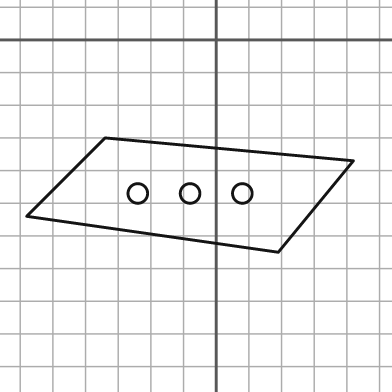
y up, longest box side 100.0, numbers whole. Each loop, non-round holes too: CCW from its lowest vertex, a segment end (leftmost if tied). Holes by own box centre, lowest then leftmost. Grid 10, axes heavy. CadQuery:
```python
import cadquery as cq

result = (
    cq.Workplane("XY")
    .moveTo(19.0, -65.0)
    .lineTo(42.0, -37.0)
    .lineTo(-34.0, -30.0)
    .lineTo(-58.0, -54.0)
    .close()
    .moveTo(-24.0, -47.0)
    .circle(3.0)
    .moveTo(-8.0, -47.0)
    .circle(3.0)
    .moveTo(8.0, -47.0)
    .circle(3.0)
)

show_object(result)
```